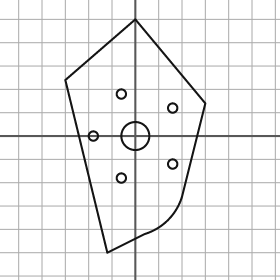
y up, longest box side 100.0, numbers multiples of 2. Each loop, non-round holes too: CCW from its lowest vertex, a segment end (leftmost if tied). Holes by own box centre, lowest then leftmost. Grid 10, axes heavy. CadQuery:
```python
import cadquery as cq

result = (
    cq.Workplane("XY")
    .moveTo(-12.0, -50.0)
    .lineTo(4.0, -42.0)
    .threePointArc((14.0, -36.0), (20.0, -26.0))
    .lineTo(30.0, 14.0)
    .lineTo(0.0, 50.0)
    .lineTo(-30.0, 24.0)
    .close()
    .moveTo(-6.0, -18.0)
    .circle(2.0)
    .moveTo(16.0, -12.0)
    .circle(2.0)
    .moveTo(-18.0, 0.0)
    .circle(2.0)
    .moveTo(0.0, 0.0)
    .circle(6.0)
    .moveTo(16.0, 12.0)
    .circle(2.0)
    .moveTo(-6.0, 18.0)
    .circle(2.0)
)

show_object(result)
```